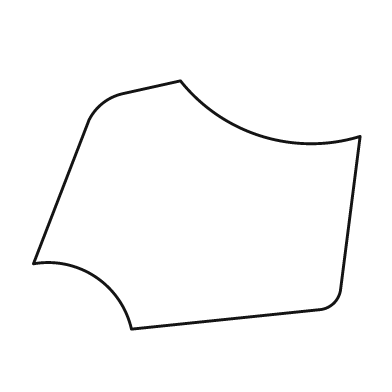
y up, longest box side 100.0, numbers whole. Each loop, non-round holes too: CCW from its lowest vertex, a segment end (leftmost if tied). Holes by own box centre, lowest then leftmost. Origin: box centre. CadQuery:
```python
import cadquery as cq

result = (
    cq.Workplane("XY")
    .moveTo(-20.0, -38.0)
    .lineTo(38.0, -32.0)
    .threePointArc((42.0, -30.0), (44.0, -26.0))
    .lineTo(50.0, 21.0)
    .threePointArc((20.0, 21.0), (-5.0, 38.0))
    .lineTo(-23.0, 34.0)
    .threePointArc((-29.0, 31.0), (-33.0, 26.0))
    .lineTo(-50.0, -18.0)
    .threePointArc((-31.0, -22.0), (-20.0, -38.0))
    .close()
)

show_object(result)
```